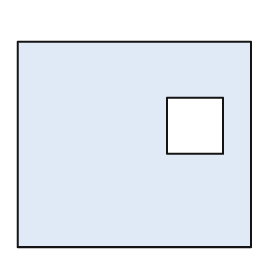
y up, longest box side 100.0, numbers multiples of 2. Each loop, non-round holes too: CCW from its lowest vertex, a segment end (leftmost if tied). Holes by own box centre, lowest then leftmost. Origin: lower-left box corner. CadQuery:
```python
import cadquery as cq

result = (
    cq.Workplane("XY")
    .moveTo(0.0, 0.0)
    .lineTo(100.0, 0.0)
    .lineTo(100.0, 88.0)
    .lineTo(0.0, 88.0)
    .close()
    .moveTo(64.0, 40.0)
    .lineTo(88.0, 40.0)
    .lineTo(88.0, 64.0)
    .lineTo(64.0, 64.0)
    .close()
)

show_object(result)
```